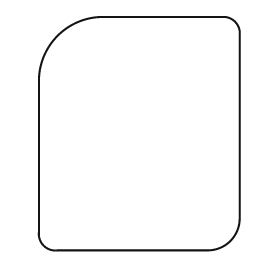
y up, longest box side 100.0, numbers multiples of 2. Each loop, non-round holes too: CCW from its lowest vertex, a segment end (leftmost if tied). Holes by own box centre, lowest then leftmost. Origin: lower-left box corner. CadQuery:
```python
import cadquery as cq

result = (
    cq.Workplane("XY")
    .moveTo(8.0, 0.0)
    .lineTo(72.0, 0.0)
    .threePointArc((82.0, 4.0), (86.0, 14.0))
    .lineTo(86.0, 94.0)
    .threePointArc((84.0, 98.0), (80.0, 100.0))
    .lineTo(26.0, 100.0)
    .threePointArc((8.0, 92.0), (0.0, 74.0))
    .lineTo(0.0, 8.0)
    .threePointArc((2.0, 2.0), (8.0, 0.0))
    .close()
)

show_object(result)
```